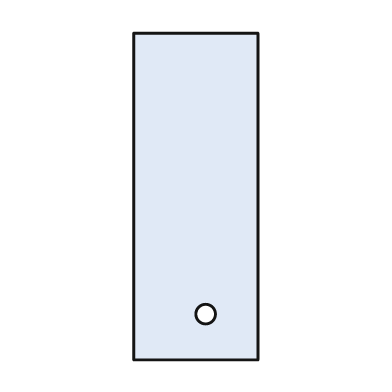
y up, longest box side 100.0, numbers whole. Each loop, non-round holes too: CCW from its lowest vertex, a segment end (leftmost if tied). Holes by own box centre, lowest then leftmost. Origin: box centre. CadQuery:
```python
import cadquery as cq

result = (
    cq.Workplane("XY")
    .moveTo(-19.0, -50.0)
    .lineTo(19.0, -50.0)
    .lineTo(19.0, 50.0)
    .lineTo(-19.0, 50.0)
    .close()
    .moveTo(3.0, -36.0)
    .circle(3.0)
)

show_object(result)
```